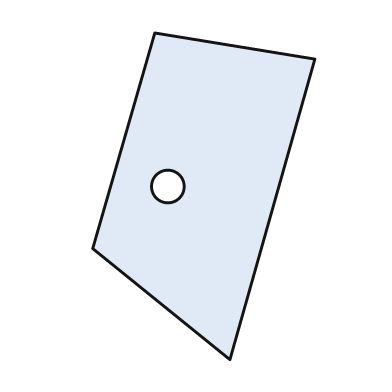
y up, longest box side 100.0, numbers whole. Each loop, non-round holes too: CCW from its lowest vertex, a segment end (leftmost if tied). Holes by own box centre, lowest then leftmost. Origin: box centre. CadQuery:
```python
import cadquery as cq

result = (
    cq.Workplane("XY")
    .moveTo(8.0, -50.0)
    .lineTo(34.0, 42.0)
    .lineTo(-15.0, 50.0)
    .lineTo(-34.0, -16.0)
    .close()
    .moveTo(-11.0, 3.0)
    .circle(5.0)
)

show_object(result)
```